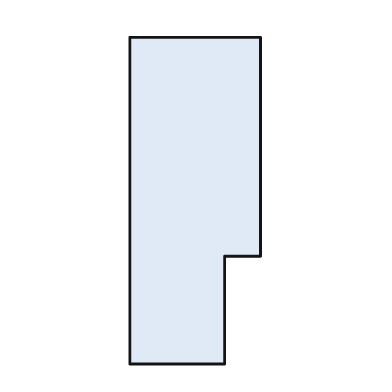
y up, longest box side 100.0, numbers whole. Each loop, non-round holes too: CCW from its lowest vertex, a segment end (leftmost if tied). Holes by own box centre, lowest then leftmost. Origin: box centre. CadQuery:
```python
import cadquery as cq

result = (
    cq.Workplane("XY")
    .moveTo(-20.0, -50.0)
    .lineTo(9.0, -50.0)
    .lineTo(9.0, -17.0)
    .lineTo(20.0, -17.0)
    .lineTo(20.0, 50.0)
    .lineTo(-20.0, 50.0)
    .close()
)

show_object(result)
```